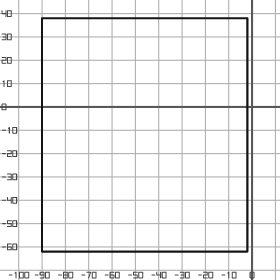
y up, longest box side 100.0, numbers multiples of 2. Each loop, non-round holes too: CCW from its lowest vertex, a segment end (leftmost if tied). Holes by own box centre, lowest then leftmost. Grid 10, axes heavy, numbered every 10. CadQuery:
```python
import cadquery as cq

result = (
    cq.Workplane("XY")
    .moveTo(-90.0, -62.0)
    .lineTo(-2.0, -62.0)
    .lineTo(-2.0, 38.0)
    .lineTo(-90.0, 38.0)
    .close()
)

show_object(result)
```